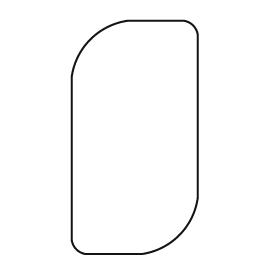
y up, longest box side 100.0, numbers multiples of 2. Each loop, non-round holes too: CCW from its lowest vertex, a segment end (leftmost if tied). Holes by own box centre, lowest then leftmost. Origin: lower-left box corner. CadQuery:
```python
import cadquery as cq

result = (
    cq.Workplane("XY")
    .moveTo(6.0, 0.0)
    .lineTo(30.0, 0.0)
    .threePointArc((46.0, 8.0), (54.0, 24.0))
    .lineTo(54.0, 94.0)
    .threePointArc((52.0, 98.0), (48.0, 100.0))
    .lineTo(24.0, 100.0)
    .threePointArc((8.0, 92.0), (0.0, 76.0))
    .lineTo(0.0, 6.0)
    .threePointArc((2.0, 2.0), (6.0, 0.0))
    .close()
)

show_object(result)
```